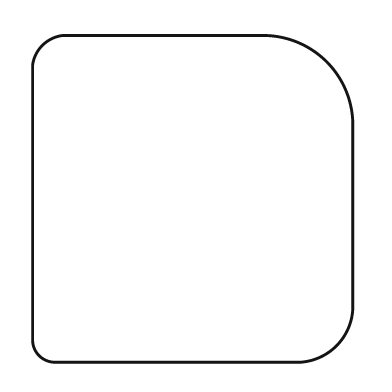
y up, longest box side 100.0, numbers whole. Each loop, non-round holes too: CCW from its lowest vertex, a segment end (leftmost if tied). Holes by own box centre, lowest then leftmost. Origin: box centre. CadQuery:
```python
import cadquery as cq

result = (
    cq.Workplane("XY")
    .moveTo(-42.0, -50.0)
    .lineTo(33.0, -50.0)
    .threePointArc((44.0, -45.0), (49.0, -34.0))
    .lineTo(49.0, 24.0)
    .threePointArc((41.0, 42.0), (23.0, 50.0))
    .lineTo(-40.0, 50.0)
    .threePointArc((-46.0, 47.0), (-49.0, 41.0))
    .lineTo(-49.0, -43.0)
    .threePointArc((-47.0, -48.0), (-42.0, -50.0))
    .close()
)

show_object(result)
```